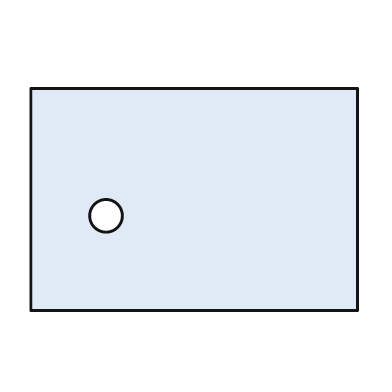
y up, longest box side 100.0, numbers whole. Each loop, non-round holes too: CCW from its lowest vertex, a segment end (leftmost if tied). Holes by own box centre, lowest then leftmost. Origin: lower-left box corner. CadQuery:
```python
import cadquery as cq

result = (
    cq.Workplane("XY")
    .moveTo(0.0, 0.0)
    .lineTo(100.0, 0.0)
    .lineTo(100.0, 68.0)
    .lineTo(0.0, 68.0)
    .close()
    .moveTo(23.0, 29.0)
    .circle(5.0)
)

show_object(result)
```